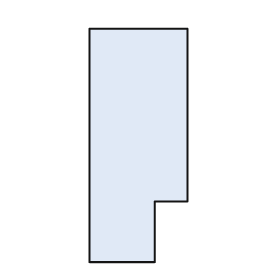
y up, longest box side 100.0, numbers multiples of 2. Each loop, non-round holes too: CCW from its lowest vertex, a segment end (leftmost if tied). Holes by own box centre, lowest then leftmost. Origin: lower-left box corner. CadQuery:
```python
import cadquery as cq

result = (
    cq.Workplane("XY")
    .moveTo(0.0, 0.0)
    .lineTo(28.0, 0.0)
    .lineTo(28.0, 26.0)
    .lineTo(42.0, 26.0)
    .lineTo(42.0, 100.0)
    .lineTo(0.0, 100.0)
    .close()
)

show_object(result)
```